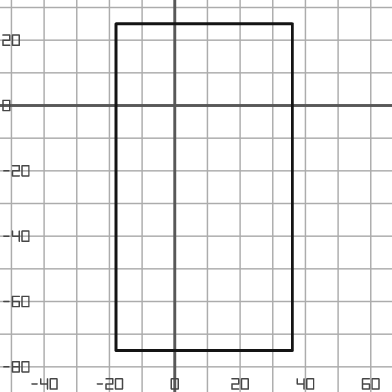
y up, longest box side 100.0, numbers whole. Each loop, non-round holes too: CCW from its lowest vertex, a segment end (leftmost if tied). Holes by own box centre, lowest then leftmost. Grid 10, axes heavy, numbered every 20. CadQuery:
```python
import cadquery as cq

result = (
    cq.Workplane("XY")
    .moveTo(-18.0, -75.0)
    .lineTo(36.0, -75.0)
    .lineTo(36.0, 25.0)
    .lineTo(-18.0, 25.0)
    .close()
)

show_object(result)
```